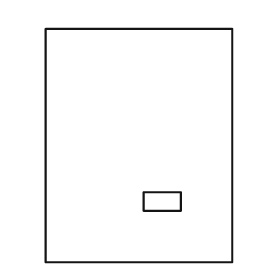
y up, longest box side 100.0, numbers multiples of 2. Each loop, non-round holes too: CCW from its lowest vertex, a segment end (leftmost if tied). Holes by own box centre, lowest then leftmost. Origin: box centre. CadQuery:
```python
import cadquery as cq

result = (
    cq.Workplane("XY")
    .moveTo(-40.0, -50.0)
    .lineTo(40.0, -50.0)
    .lineTo(40.0, 50.0)
    .lineTo(-40.0, 50.0)
    .close()
    .moveTo(2.0, -28.0)
    .lineTo(18.0, -28.0)
    .lineTo(18.0, -20.0)
    .lineTo(2.0, -20.0)
    .close()
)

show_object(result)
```